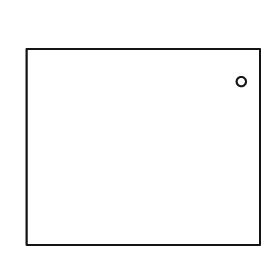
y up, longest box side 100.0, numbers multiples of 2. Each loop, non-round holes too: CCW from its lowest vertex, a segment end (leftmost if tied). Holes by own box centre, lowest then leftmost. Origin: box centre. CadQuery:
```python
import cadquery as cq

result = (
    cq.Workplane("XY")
    .moveTo(-50.0, -42.0)
    .lineTo(50.0, -42.0)
    .lineTo(50.0, 42.0)
    .lineTo(-50.0, 42.0)
    .close()
    .moveTo(42.0, 28.0)
    .circle(2.0)
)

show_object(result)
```